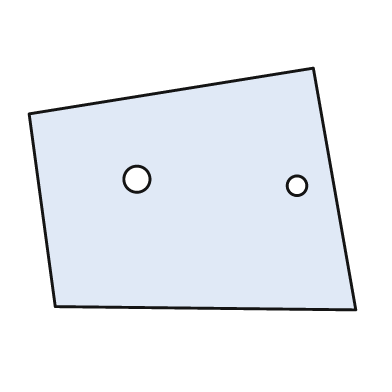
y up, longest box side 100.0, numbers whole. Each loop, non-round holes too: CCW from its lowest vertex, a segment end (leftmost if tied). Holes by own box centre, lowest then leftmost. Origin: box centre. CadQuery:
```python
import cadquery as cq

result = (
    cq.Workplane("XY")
    .moveTo(50.0, -37.0)
    .lineTo(37.0, 37.0)
    .lineTo(-50.0, 23.0)
    .lineTo(-42.0, -36.0)
    .close()
    .moveTo(32.0, 1.0)
    .circle(3.0)
    .moveTo(-17.0, 3.0)
    .circle(4.0)
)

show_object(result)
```